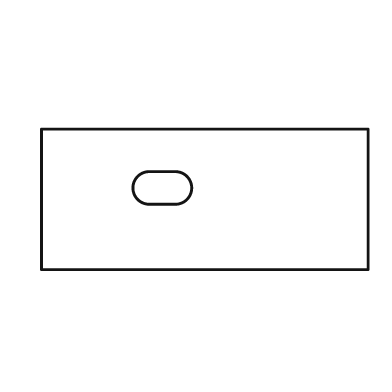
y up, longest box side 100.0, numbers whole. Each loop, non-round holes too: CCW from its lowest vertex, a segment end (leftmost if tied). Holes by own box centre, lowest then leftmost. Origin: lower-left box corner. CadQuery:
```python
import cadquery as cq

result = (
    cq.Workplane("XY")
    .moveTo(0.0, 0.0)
    .lineTo(100.0, 0.0)
    .lineTo(100.0, 43.0)
    .lineTo(0.0, 43.0)
    .close()
    .moveTo(33.0, 20.0)
    .lineTo(41.0, 20.0)
    .threePointArc((46.0, 25.0), (41.0, 30.0))
    .lineTo(33.0, 30.0)
    .threePointArc((28.0, 25.0), (33.0, 20.0))
    .close()
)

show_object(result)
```